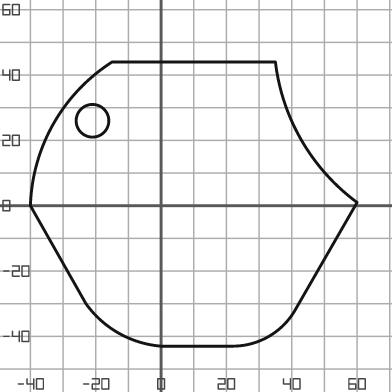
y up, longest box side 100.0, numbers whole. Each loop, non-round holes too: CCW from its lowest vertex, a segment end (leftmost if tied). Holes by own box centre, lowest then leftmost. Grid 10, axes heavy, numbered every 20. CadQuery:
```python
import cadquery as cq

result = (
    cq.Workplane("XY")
    .moveTo(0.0, -43.0)
    .lineTo(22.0, -43.0)
    .threePointArc((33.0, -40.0), (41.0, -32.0))
    .lineTo(60.0, 1.0)
    .threePointArc((43.0, 20.0), (35.0, 44.0))
    .lineTo(-15.0, 44.0)
    .threePointArc((-33.0, 25.0), (-40.0, 0.0))
    .lineTo(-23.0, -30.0)
    .threePointArc((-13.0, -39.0), (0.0, -43.0))
    .close()
    .moveTo(-21.0, 26.0)
    .circle(5.0)
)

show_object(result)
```